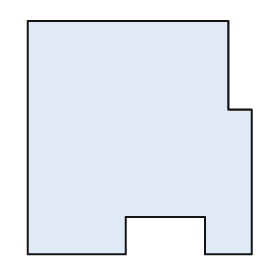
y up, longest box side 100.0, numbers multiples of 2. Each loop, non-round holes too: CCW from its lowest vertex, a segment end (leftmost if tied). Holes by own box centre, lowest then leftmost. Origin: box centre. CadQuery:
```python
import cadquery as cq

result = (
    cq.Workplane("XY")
    .moveTo(-48.0, -50.0)
    .lineTo(-6.0, -50.0)
    .lineTo(-6.0, -34.0)
    .lineTo(28.0, -34.0)
    .lineTo(28.0, -50.0)
    .lineTo(48.0, -50.0)
    .lineTo(48.0, 12.0)
    .lineTo(38.0, 12.0)
    .lineTo(38.0, 50.0)
    .lineTo(-48.0, 50.0)
    .close()
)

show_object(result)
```